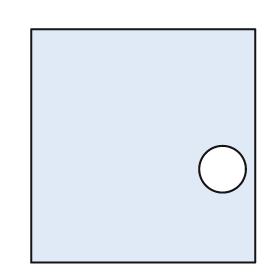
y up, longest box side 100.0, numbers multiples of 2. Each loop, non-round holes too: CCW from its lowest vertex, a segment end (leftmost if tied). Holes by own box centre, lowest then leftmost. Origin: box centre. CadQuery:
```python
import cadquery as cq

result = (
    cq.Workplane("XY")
    .moveTo(-48.0, -50.0)
    .lineTo(48.0, -50.0)
    .lineTo(48.0, 50.0)
    .lineTo(-48.0, 50.0)
    .close()
    .moveTo(34.0, -10.0)
    .circle(10.0)
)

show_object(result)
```